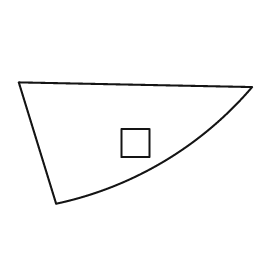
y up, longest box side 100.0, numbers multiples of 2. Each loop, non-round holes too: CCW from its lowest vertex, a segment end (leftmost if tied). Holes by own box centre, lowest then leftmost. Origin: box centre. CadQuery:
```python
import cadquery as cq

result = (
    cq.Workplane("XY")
    .moveTo(-34.0, -26.0)
    .threePointArc((12.0, -8.0), (50.0, 24.0))
    .lineTo(-50.0, 26.0)
    .close()
    .moveTo(-6.0, -6.0)
    .lineTo(6.0, -6.0)
    .lineTo(6.0, 6.0)
    .lineTo(-6.0, 6.0)
    .close()
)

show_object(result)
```